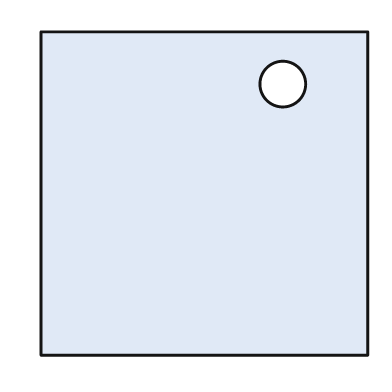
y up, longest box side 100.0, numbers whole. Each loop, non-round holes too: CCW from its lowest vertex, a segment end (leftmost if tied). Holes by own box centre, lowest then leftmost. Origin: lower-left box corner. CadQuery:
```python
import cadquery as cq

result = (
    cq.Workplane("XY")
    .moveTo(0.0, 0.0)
    .lineTo(100.0, 0.0)
    .lineTo(100.0, 99.0)
    .lineTo(0.0, 99.0)
    .close()
    .moveTo(74.0, 83.0)
    .circle(7.0)
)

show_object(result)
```